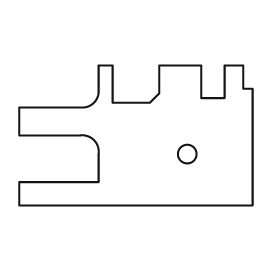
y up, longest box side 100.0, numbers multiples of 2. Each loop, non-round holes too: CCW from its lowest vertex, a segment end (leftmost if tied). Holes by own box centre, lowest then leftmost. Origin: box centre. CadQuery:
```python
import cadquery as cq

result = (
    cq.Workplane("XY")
    .moveTo(-50.0, -30.0)
    .lineTo(50.0, -30.0)
    .lineTo(50.0, 20.0)
    .lineTo(46.0, 20.0)
    .lineTo(46.0, 30.0)
    .lineTo(38.0, 30.0)
    .lineTo(38.0, 16.0)
    .lineTo(28.0, 16.0)
    .lineTo(28.0, 30.0)
    .lineTo(10.0, 30.0)
    .lineTo(10.0, 18.0)
    .lineTo(6.0, 14.0)
    .lineTo(-10.0, 14.0)
    .lineTo(-10.0, 30.0)
    .lineTo(-16.0, 30.0)
    .lineTo(-16.0, 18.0)
    .threePointArc((-18.0, 14.0), (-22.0, 12.0))
    .lineTo(-50.0, 12.0)
    .lineTo(-50.0, 0.0)
    .lineTo(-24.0, 0.0)
    .threePointArc((-18.0, -2.0), (-16.0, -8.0))
    .lineTo(-16.0, -20.0)
    .lineTo(-50.0, -20.0)
    .close()
    .moveTo(22.0, -8.0)
    .circle(4.0)
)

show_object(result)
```